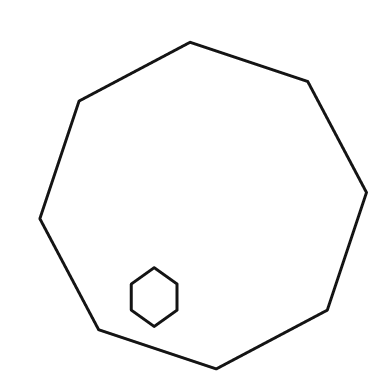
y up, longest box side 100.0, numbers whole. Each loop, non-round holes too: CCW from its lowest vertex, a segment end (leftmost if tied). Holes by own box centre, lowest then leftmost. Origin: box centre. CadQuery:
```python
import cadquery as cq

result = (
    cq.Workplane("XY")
    .moveTo(4.0, -50.0)
    .lineTo(38.0, -32.0)
    .lineTo(50.0, 4.0)
    .lineTo(32.0, 38.0)
    .lineTo(-4.0, 50.0)
    .lineTo(-38.0, 32.0)
    .lineTo(-50.0, -4.0)
    .lineTo(-32.0, -38.0)
    .close()
    .moveTo(-15.0, -37.0)
    .lineTo(-8.0, -32.0)
    .lineTo(-8.0, -24.0)
    .lineTo(-15.0, -19.0)
    .lineTo(-22.0, -24.0)
    .lineTo(-22.0, -32.0)
    .close()
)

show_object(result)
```